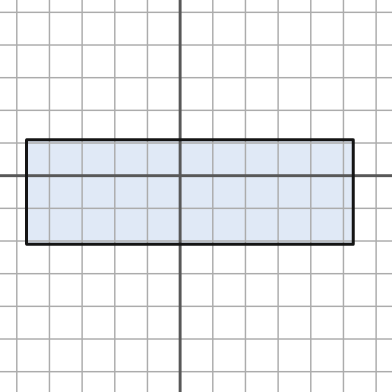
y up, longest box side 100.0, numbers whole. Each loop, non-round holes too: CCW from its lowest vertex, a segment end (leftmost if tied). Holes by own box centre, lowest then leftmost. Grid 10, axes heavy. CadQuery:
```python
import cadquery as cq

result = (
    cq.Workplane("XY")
    .moveTo(-47.0, -21.0)
    .lineTo(53.0, -21.0)
    .lineTo(53.0, 11.0)
    .lineTo(-47.0, 11.0)
    .close()
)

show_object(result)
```